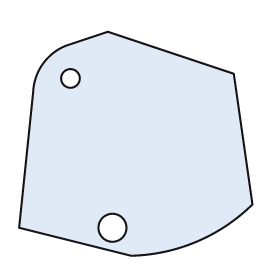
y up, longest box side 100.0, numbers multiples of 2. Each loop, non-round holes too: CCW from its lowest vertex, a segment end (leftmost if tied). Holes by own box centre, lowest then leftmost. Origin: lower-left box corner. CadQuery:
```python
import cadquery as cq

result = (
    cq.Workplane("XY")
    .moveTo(48.0, 0.0)
    .threePointArc((76.0, 6.0), (100.0, 22.0))
    .lineTo(92.0, 78.0)
    .lineTo(38.0, 96.0)
    .lineTo(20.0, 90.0)
    .threePointArc((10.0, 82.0), (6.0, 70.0))
    .lineTo(0.0, 12.0)
    .close()
    .moveTo(40.0, 12.0)
    .circle(6.0)
    .moveTo(22.0, 76.0)
    .circle(4.0)
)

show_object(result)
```